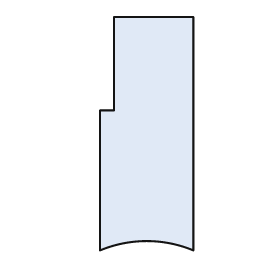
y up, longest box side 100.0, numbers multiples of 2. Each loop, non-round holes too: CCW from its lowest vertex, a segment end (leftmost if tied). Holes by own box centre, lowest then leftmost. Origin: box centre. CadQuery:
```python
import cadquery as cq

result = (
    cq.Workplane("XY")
    .moveTo(-20.0, -50.0)
    .threePointArc((0.0, -46.0), (20.0, -50.0))
    .lineTo(20.0, 50.0)
    .lineTo(-14.0, 50.0)
    .lineTo(-14.0, 10.0)
    .lineTo(-20.0, 10.0)
    .close()
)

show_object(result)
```